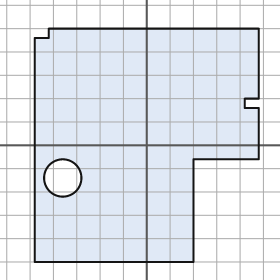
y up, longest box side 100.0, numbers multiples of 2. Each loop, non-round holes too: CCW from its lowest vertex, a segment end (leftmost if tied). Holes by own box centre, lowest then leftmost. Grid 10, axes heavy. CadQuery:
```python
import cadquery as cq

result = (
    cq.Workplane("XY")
    .moveTo(-48.0, -50.0)
    .lineTo(20.0, -50.0)
    .lineTo(20.0, -6.0)
    .lineTo(48.0, -6.0)
    .lineTo(48.0, 16.0)
    .lineTo(42.0, 16.0)
    .lineTo(42.0, 20.0)
    .lineTo(48.0, 20.0)
    .lineTo(48.0, 50.0)
    .lineTo(-42.0, 50.0)
    .lineTo(-42.0, 46.0)
    .lineTo(-48.0, 46.0)
    .close()
    .moveTo(-36.0, -14.0)
    .circle(8.0)
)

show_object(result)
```